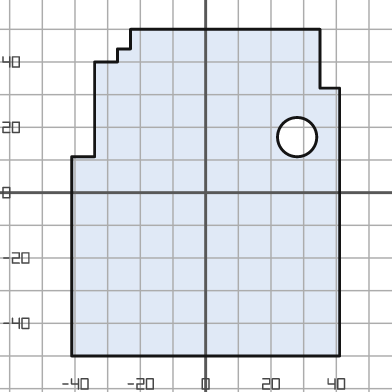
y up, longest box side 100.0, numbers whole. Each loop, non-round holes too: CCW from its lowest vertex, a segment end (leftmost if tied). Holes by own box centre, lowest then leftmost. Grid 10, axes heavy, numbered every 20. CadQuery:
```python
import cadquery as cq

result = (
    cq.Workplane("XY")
    .moveTo(-41.0, -50.0)
    .lineTo(41.0, -50.0)
    .lineTo(41.0, 32.0)
    .lineTo(35.0, 32.0)
    .lineTo(35.0, 50.0)
    .lineTo(-23.0, 50.0)
    .lineTo(-23.0, 44.0)
    .lineTo(-27.0, 44.0)
    .lineTo(-27.0, 40.0)
    .lineTo(-34.0, 40.0)
    .lineTo(-34.0, 11.0)
    .lineTo(-41.0, 11.0)
    .close()
    .moveTo(28.0, 17.0)
    .circle(6.0)
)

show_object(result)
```